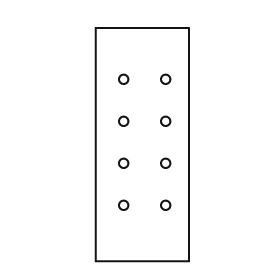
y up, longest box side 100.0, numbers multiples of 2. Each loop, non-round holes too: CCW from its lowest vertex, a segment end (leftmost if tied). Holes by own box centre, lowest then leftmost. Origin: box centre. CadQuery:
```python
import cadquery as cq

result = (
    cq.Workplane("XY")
    .moveTo(-20.0, -50.0)
    .lineTo(20.0, -50.0)
    .lineTo(20.0, 50.0)
    .lineTo(-20.0, 50.0)
    .close()
    .moveTo(-8.0, -26.0)
    .circle(2.0)
    .moveTo(10.0, -26.0)
    .circle(2.0)
    .moveTo(-8.0, -8.0)
    .circle(2.0)
    .moveTo(10.0, -8.0)
    .circle(2.0)
    .moveTo(-8.0, 10.0)
    .circle(2.0)
    .moveTo(10.0, 10.0)
    .circle(2.0)
    .moveTo(-8.0, 28.0)
    .circle(2.0)
    .moveTo(10.0, 28.0)
    .circle(2.0)
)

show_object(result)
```